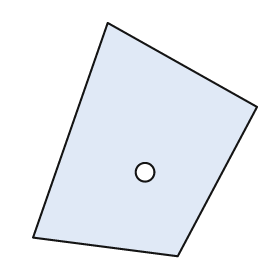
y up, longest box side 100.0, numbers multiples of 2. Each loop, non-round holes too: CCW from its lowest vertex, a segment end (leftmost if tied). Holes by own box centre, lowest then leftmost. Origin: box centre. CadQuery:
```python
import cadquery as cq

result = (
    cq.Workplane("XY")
    .moveTo(14.0, -50.0)
    .lineTo(48.0, 14.0)
    .lineTo(-16.0, 50.0)
    .lineTo(-48.0, -42.0)
    .close()
    .moveTo(0.0, -14.0)
    .circle(4.0)
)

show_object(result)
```